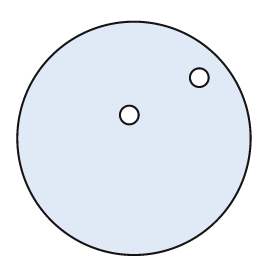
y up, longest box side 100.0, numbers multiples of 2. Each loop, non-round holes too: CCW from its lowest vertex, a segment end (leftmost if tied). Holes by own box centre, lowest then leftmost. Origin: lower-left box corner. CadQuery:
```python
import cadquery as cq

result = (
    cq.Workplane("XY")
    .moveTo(50.0, 50.0)
    .circle(50.0)
    .moveTo(48.0, 60.0)
    .circle(4.0)
    .moveTo(78.0, 76.0)
    .circle(4.0)
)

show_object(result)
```